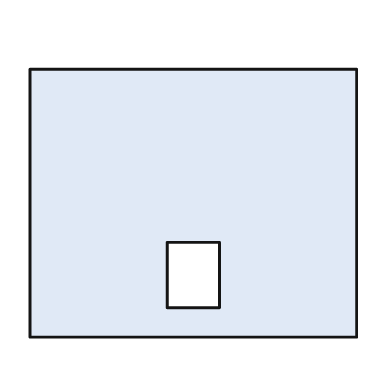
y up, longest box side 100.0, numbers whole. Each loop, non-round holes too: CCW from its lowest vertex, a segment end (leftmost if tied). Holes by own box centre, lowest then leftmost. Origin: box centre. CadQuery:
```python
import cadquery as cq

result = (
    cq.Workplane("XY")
    .moveTo(-50.0, -41.0)
    .lineTo(50.0, -41.0)
    .lineTo(50.0, 41.0)
    .lineTo(-50.0, 41.0)
    .close()
    .moveTo(-8.0, -32.0)
    .lineTo(8.0, -32.0)
    .lineTo(8.0, -12.0)
    .lineTo(-8.0, -12.0)
    .close()
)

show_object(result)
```